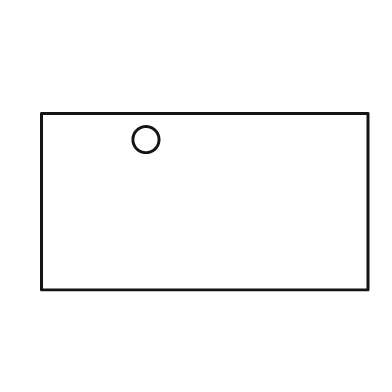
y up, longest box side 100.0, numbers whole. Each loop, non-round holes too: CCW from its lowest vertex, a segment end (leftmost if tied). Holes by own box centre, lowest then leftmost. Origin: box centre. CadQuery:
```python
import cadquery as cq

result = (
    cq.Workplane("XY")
    .moveTo(-50.0, -27.0)
    .lineTo(50.0, -27.0)
    .lineTo(50.0, 27.0)
    .lineTo(-50.0, 27.0)
    .close()
    .moveTo(-18.0, 19.0)
    .circle(4.0)
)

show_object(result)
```